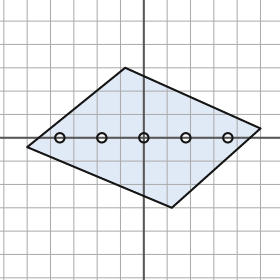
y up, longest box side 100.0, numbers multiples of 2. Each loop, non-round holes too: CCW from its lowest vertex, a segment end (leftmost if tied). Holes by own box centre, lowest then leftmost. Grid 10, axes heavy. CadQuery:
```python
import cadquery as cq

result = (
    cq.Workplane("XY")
    .moveTo(12.0, -30.0)
    .lineTo(50.0, 4.0)
    .lineTo(-8.0, 30.0)
    .lineTo(-50.0, -4.0)
    .close()
    .moveTo(-36.0, 0.0)
    .circle(2.0)
    .moveTo(-18.0, 0.0)
    .circle(2.0)
    .moveTo(0.0, 0.0)
    .circle(2.0)
    .moveTo(18.0, 0.0)
    .circle(2.0)
    .moveTo(36.0, 0.0)
    .circle(2.0)
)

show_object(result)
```